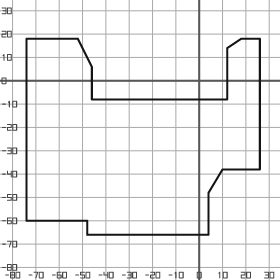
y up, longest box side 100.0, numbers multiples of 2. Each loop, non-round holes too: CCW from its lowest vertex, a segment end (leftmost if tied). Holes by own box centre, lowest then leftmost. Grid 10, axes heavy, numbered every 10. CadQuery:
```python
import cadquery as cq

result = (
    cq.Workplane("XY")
    .moveTo(-48.0, -66.0)
    .lineTo(4.0, -66.0)
    .lineTo(4.0, -48.0)
    .lineTo(10.0, -38.0)
    .lineTo(26.0, -38.0)
    .lineTo(26.0, 18.0)
    .lineTo(18.0, 18.0)
    .lineTo(12.0, 14.0)
    .lineTo(12.0, -8.0)
    .lineTo(-46.0, -8.0)
    .lineTo(-46.0, 6.0)
    .lineTo(-52.0, 18.0)
    .lineTo(-74.0, 18.0)
    .lineTo(-74.0, -60.0)
    .lineTo(-48.0, -60.0)
    .close()
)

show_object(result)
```